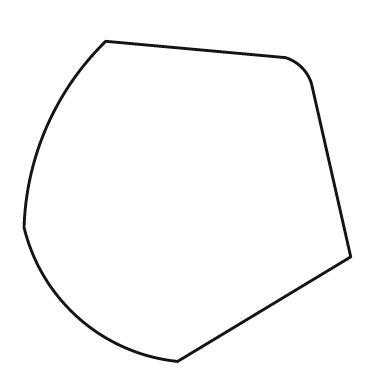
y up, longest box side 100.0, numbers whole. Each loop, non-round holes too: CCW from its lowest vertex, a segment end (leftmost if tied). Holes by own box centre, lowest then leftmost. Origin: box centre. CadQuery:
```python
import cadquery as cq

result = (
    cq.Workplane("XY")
    .moveTo(-3.0, -49.0)
    .lineTo(50.0, -17.0)
    .lineTo(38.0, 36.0)
    .threePointArc((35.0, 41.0), (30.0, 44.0))
    .lineTo(-25.0, 49.0)
    .threePointArc((-43.0, 23.0), (-50.0, -8.0))
    .threePointArc((-33.0, -36.0), (-3.0, -49.0))
    .close()
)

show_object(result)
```